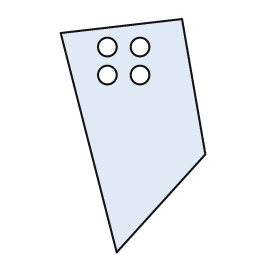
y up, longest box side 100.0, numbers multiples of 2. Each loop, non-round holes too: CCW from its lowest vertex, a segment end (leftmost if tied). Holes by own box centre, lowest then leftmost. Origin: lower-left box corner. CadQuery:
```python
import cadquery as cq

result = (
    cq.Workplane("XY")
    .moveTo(24.0, 0.0)
    .lineTo(62.0, 42.0)
    .lineTo(52.0, 100.0)
    .lineTo(0.0, 94.0)
    .close()
    .moveTo(20.0, 76.0)
    .circle(4.0)
    .moveTo(34.0, 76.0)
    .circle(4.0)
    .moveTo(20.0, 88.0)
    .circle(4.0)
    .moveTo(34.0, 88.0)
    .circle(4.0)
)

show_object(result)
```